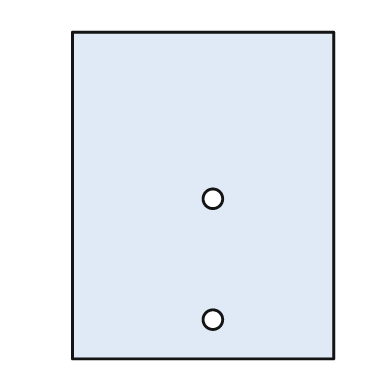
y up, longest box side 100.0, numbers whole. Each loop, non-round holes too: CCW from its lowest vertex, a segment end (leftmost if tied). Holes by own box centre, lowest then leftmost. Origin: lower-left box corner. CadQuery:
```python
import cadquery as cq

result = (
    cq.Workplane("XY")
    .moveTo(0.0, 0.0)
    .lineTo(80.0, 0.0)
    .lineTo(80.0, 100.0)
    .lineTo(0.0, 100.0)
    .close()
    .moveTo(43.0, 12.0)
    .circle(3.0)
    .moveTo(43.0, 49.0)
    .circle(3.0)
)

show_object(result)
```